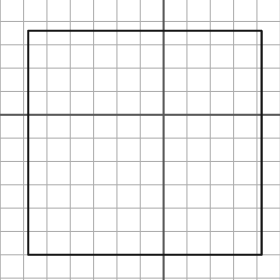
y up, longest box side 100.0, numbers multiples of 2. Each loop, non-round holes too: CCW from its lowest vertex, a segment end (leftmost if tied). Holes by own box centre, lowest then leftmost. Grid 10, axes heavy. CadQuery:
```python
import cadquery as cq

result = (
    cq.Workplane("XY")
    .moveTo(-58.0, -60.0)
    .lineTo(42.0, -60.0)
    .lineTo(42.0, 36.0)
    .lineTo(-58.0, 36.0)
    .close()
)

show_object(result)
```